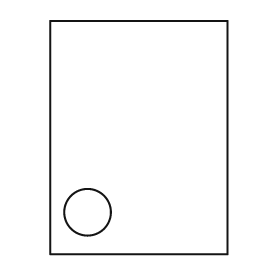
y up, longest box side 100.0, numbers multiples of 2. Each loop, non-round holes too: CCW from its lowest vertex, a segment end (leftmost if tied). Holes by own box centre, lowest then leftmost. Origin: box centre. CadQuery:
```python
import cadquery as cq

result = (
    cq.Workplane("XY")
    .moveTo(-38.0, -50.0)
    .lineTo(38.0, -50.0)
    .lineTo(38.0, 50.0)
    .lineTo(-38.0, 50.0)
    .close()
    .moveTo(-22.0, -32.0)
    .circle(10.0)
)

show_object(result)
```